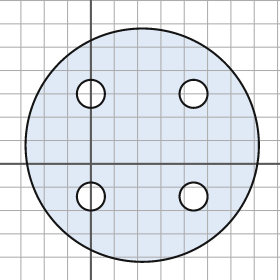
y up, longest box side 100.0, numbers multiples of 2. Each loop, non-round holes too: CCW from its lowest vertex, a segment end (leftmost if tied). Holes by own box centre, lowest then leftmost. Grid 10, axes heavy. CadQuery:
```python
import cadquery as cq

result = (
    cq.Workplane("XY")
    .moveTo(22.0, 8.0)
    .circle(50.0)
    .moveTo(0.0, -14.0)
    .circle(6.0)
    .moveTo(44.0, -14.0)
    .circle(6.0)
    .moveTo(0.0, 30.0)
    .circle(6.0)
    .moveTo(44.0, 30.0)
    .circle(6.0)
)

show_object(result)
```